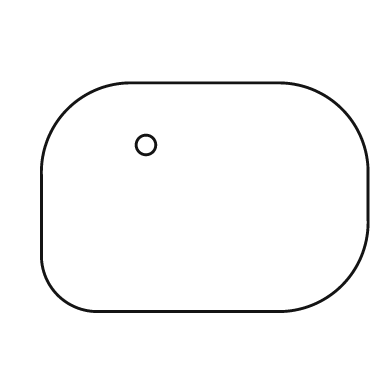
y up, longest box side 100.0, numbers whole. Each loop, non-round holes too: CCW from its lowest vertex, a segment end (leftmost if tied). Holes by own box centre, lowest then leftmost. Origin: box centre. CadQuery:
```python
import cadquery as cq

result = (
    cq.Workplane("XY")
    .moveTo(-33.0, -35.0)
    .lineTo(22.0, -35.0)
    .threePointArc((42.0, -27.0), (50.0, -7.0))
    .lineTo(50.0, 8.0)
    .threePointArc((42.0, 27.0), (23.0, 35.0))
    .lineTo(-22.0, 35.0)
    .threePointArc((-42.0, 27.0), (-50.0, 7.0))
    .lineTo(-50.0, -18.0)
    .threePointArc((-45.0, -30.0), (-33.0, -35.0))
    .close()
    .moveTo(-18.0, 16.0)
    .circle(3.0)
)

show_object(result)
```